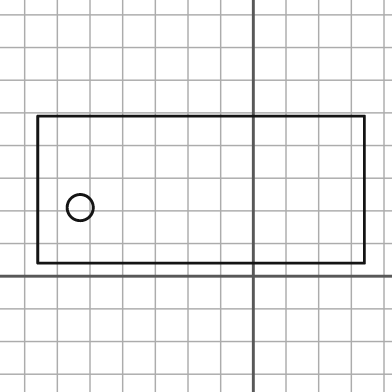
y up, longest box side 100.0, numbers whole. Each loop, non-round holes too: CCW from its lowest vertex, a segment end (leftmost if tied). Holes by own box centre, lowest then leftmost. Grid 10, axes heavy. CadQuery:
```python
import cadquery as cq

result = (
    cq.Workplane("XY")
    .moveTo(-66.0, 4.0)
    .lineTo(34.0, 4.0)
    .lineTo(34.0, 49.0)
    .lineTo(-66.0, 49.0)
    .close()
    .moveTo(-53.0, 21.0)
    .circle(4.0)
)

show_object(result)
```